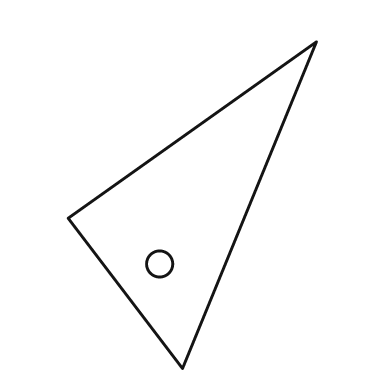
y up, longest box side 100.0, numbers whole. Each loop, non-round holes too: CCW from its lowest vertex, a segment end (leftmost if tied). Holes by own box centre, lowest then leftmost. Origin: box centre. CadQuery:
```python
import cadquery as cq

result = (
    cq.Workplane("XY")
    .moveTo(-3.0, -50.0)
    .lineTo(38.0, 50.0)
    .lineTo(-38.0, -4.0)
    .close()
    .moveTo(-10.0, -18.0)
    .circle(4.0)
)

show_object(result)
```